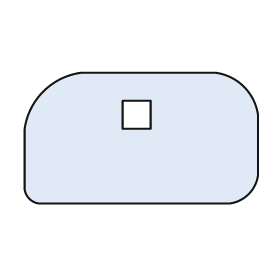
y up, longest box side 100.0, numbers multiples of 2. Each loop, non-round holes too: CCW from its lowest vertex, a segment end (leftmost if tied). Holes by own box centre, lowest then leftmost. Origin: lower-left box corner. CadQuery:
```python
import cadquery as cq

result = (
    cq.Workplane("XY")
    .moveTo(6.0, 0.0)
    .lineTo(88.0, 0.0)
    .threePointArc((96.0, 4.0), (100.0, 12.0))
    .lineTo(100.0, 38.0)
    .threePointArc((94.0, 50.0), (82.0, 56.0))
    .lineTo(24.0, 56.0)
    .threePointArc((8.0, 48.0), (0.0, 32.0))
    .lineTo(0.0, 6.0)
    .threePointArc((2.0, 2.0), (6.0, 0.0))
    .close()
    .moveTo(42.0, 32.0)
    .lineTo(54.0, 32.0)
    .lineTo(54.0, 44.0)
    .lineTo(42.0, 44.0)
    .close()
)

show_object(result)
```